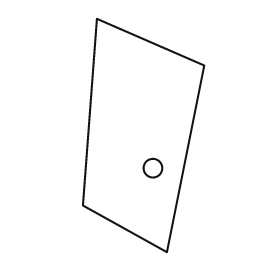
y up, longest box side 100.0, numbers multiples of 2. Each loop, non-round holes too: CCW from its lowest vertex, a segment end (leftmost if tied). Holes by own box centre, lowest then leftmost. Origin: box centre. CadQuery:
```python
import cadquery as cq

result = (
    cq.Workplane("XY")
    .moveTo(10.0, -50.0)
    .lineTo(26.0, 30.0)
    .lineTo(-20.0, 50.0)
    .lineTo(-26.0, -30.0)
    .close()
    .moveTo(4.0, -14.0)
    .circle(4.0)
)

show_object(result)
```